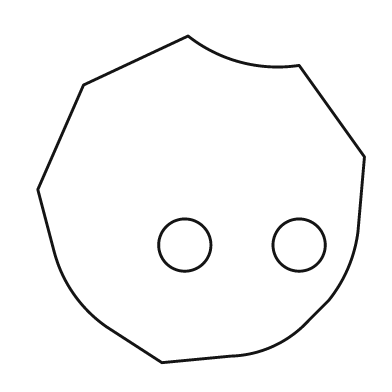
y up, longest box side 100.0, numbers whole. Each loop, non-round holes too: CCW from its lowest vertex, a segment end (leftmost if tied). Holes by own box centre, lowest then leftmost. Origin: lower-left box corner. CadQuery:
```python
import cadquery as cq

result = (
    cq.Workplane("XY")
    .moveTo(38.0, 0.0)
    .lineTo(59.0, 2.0)
    .threePointArc((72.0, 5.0), (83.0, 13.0))
    .lineTo(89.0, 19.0)
    .threePointArc((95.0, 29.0), (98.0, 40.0))
    .lineTo(100.0, 63.0)
    .lineTo(80.0, 91.0)
    .threePointArc((62.0, 92.0), (46.0, 100.0))
    .lineTo(14.0, 85.0)
    .lineTo(0.0, 53.0)
    .lineTo(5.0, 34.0)
    .threePointArc((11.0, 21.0), (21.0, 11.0))
    .close()
    .moveTo(45.0, 36.0)
    .circle(8.0)
    .moveTo(80.0, 36.0)
    .circle(8.0)
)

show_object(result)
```